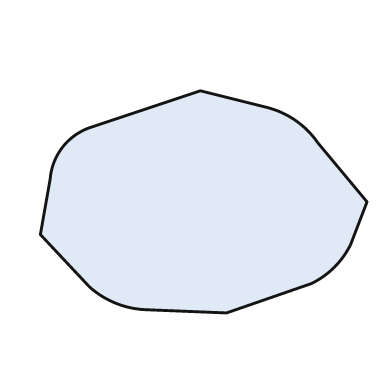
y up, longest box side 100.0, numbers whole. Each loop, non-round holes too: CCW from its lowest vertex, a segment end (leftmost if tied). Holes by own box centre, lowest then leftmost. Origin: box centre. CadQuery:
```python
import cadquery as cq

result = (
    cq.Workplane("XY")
    .moveTo(7.0, -34.0)
    .lineTo(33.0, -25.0)
    .threePointArc((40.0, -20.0), (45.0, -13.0))
    .lineTo(50.0, 0.0)
    .lineTo(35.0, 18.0)
    .threePointArc((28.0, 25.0), (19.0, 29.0))
    .lineTo(-1.0, 34.0)
    .lineTo(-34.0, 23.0)
    .threePointArc((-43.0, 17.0), (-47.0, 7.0))
    .lineTo(-50.0, -10.0)
    .lineTo(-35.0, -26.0)
    .threePointArc((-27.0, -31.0), (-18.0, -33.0))
    .close()
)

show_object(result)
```